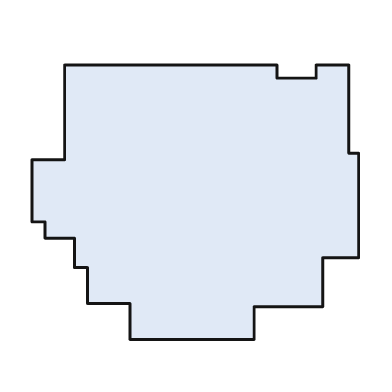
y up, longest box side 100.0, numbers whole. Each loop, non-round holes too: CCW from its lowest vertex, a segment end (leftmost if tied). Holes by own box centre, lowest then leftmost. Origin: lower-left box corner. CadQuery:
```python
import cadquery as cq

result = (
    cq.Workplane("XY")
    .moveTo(30.0, 0.0)
    .lineTo(68.0, 0.0)
    .lineTo(68.0, 10.0)
    .lineTo(89.0, 10.0)
    .lineTo(89.0, 25.0)
    .lineTo(100.0, 25.0)
    .lineTo(100.0, 57.0)
    .lineTo(97.0, 57.0)
    .lineTo(97.0, 84.0)
    .lineTo(87.0, 84.0)
    .lineTo(87.0, 80.0)
    .lineTo(75.0, 80.0)
    .lineTo(75.0, 84.0)
    .lineTo(10.0, 84.0)
    .lineTo(10.0, 55.0)
    .lineTo(0.0, 55.0)
    .lineTo(0.0, 36.0)
    .lineTo(4.0, 36.0)
    .lineTo(4.0, 31.0)
    .lineTo(13.0, 31.0)
    .lineTo(13.0, 22.0)
    .lineTo(17.0, 22.0)
    .lineTo(17.0, 11.0)
    .lineTo(30.0, 11.0)
    .close()
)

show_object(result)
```